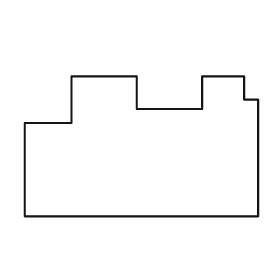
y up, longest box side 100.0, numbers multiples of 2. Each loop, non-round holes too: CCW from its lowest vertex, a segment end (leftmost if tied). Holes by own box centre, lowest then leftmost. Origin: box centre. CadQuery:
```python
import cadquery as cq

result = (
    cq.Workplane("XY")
    .moveTo(-50.0, -30.0)
    .lineTo(50.0, -30.0)
    .lineTo(50.0, 20.0)
    .lineTo(44.0, 20.0)
    .lineTo(44.0, 30.0)
    .lineTo(26.0, 30.0)
    .lineTo(26.0, 16.0)
    .lineTo(-2.0, 16.0)
    .lineTo(-2.0, 30.0)
    .lineTo(-30.0, 30.0)
    .lineTo(-30.0, 10.0)
    .lineTo(-50.0, 10.0)
    .close()
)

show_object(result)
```